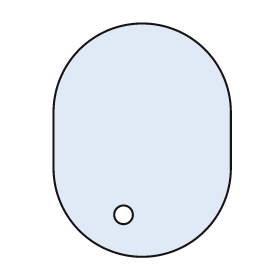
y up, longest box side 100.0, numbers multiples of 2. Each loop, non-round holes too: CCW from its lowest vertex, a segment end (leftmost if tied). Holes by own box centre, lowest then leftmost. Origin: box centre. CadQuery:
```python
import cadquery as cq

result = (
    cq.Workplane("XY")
    .moveTo(-38.0, -12.0)
    .threePointArc((0.0, -50.0), (38.0, -12.0))
    .lineTo(38.0, 12.0)
    .threePointArc((0.0, 50.0), (-38.0, 12.0))
    .close()
    .moveTo(-8.0, -32.0)
    .circle(4.0)
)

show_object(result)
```